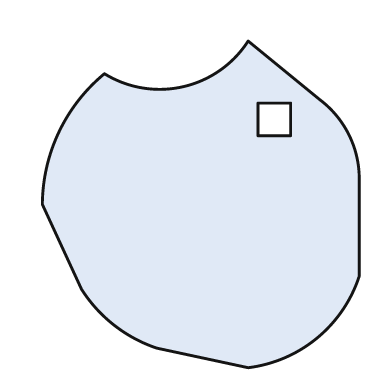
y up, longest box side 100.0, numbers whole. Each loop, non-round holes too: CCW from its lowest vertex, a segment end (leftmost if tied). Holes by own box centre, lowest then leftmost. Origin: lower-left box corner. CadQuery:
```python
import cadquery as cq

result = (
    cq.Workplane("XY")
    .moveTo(63.0, 0.0)
    .threePointArc((84.0, 9.0), (97.0, 28.0))
    .lineTo(97.0, 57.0)
    .threePointArc((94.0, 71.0), (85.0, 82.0))
    .lineTo(63.0, 100.0)
    .threePointArc((43.0, 86.0), (19.0, 90.0))
    .threePointArc((5.0, 72.0), (0.0, 50.0))
    .lineTo(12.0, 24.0)
    .threePointArc((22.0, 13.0), (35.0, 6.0))
    .close()
    .moveTo(66.0, 71.0)
    .lineTo(76.0, 71.0)
    .lineTo(76.0, 81.0)
    .lineTo(66.0, 81.0)
    .close()
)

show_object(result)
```